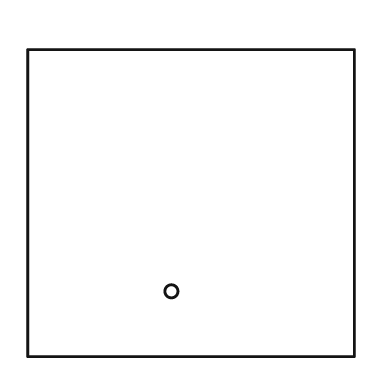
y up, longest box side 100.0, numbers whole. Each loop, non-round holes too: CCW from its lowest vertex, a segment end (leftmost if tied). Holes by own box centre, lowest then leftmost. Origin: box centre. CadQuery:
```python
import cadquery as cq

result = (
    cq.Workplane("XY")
    .moveTo(-50.0, -47.0)
    .lineTo(50.0, -47.0)
    .lineTo(50.0, 47.0)
    .lineTo(-50.0, 47.0)
    .close()
    .moveTo(-6.0, -27.0)
    .circle(2.0)
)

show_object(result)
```